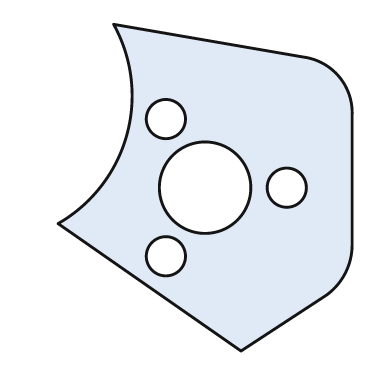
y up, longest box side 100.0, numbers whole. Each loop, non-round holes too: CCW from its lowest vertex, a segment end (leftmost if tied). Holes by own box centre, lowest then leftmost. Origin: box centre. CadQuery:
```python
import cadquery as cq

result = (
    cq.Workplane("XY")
    .moveTo(11.0, -50.0)
    .lineTo(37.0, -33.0)
    .threePointArc((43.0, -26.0), (45.0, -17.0))
    .lineTo(45.0, 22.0)
    .threePointArc((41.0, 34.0), (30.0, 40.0))
    .lineTo(-28.0, 50.0)
    .threePointArc((-24.0, 16.0), (-45.0, -11.0))
    .close()
    .moveTo(-12.0, -21.0)
    .circle(6.0)
    .moveTo(0.0, 0.0)
    .circle(14.0)
    .moveTo(25.0, 0.0)
    .circle(6.0)
    .moveTo(-12.0, 21.0)
    .circle(6.0)
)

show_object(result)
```